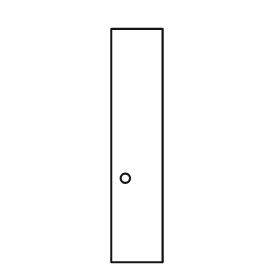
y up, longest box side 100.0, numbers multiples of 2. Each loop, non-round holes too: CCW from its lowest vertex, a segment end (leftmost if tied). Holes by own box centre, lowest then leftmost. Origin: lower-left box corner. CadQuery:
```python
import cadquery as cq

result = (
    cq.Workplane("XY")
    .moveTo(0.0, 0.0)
    .lineTo(22.0, 0.0)
    .lineTo(22.0, 100.0)
    .lineTo(0.0, 100.0)
    .close()
    .moveTo(6.0, 36.0)
    .circle(2.0)
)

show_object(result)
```